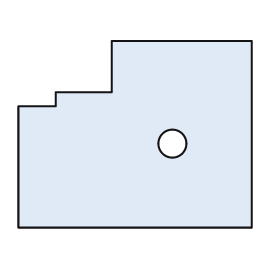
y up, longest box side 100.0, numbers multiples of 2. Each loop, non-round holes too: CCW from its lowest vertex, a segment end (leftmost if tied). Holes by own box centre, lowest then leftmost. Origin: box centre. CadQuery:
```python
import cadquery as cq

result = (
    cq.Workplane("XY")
    .moveTo(-50.0, -40.0)
    .lineTo(50.0, -40.0)
    .lineTo(50.0, 40.0)
    .lineTo(-10.0, 40.0)
    .lineTo(-10.0, 18.0)
    .lineTo(-34.0, 18.0)
    .lineTo(-34.0, 12.0)
    .lineTo(-50.0, 12.0)
    .close()
    .moveTo(16.0, -4.0)
    .circle(6.0)
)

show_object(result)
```